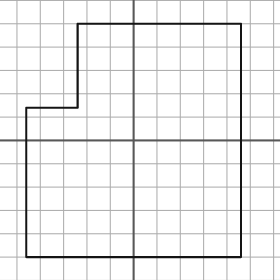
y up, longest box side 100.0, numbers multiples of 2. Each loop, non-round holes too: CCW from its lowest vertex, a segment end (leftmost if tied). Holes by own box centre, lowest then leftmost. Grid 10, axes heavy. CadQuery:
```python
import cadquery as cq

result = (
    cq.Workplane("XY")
    .moveTo(-46.0, -50.0)
    .lineTo(46.0, -50.0)
    .lineTo(46.0, 50.0)
    .lineTo(-24.0, 50.0)
    .lineTo(-24.0, 14.0)
    .lineTo(-46.0, 14.0)
    .close()
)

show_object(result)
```